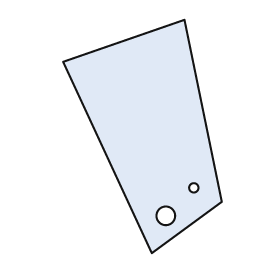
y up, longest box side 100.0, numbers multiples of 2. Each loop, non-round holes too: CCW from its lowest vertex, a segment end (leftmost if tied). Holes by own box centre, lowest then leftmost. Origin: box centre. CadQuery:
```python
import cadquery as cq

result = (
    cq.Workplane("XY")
    .moveTo(4.0, -50.0)
    .lineTo(34.0, -28.0)
    .lineTo(18.0, 50.0)
    .lineTo(-34.0, 32.0)
    .close()
    .moveTo(10.0, -34.0)
    .circle(4.0)
    .moveTo(22.0, -22.0)
    .circle(2.0)
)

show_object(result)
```